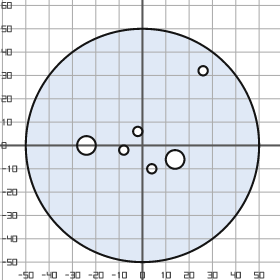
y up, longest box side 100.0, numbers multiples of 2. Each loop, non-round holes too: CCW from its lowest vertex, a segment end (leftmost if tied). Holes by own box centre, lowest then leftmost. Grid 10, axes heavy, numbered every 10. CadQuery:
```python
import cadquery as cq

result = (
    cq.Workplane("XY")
    .moveTo(0.0, 0.0)
    .circle(50.0)
    .moveTo(4.0, -10.0)
    .circle(2.0)
    .moveTo(14.0, -6.0)
    .circle(4.0)
    .moveTo(-8.0, -2.0)
    .circle(2.0)
    .moveTo(-24.0, 0.0)
    .circle(4.0)
    .moveTo(-2.0, 6.0)
    .circle(2.0)
    .moveTo(26.0, 32.0)
    .circle(2.0)
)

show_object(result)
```